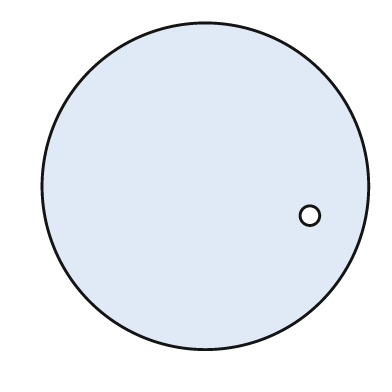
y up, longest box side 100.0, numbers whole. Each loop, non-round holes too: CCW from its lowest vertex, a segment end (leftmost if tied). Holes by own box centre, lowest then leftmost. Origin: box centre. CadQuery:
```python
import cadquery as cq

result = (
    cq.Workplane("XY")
    .moveTo(0.0, 0.0)
    .circle(50.0)
    .moveTo(32.0, -9.0)
    .circle(3.0)
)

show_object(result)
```